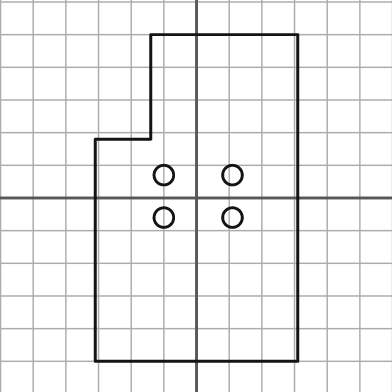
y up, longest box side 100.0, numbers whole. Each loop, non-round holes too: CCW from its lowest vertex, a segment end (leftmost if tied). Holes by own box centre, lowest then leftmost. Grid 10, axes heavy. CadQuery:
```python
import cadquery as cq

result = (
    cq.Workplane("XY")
    .moveTo(-31.0, -50.0)
    .lineTo(31.0, -50.0)
    .lineTo(31.0, 50.0)
    .lineTo(-14.0, 50.0)
    .lineTo(-14.0, 18.0)
    .lineTo(-31.0, 18.0)
    .close()
    .moveTo(-10.0, -6.0)
    .circle(3.0)
    .moveTo(11.0, -6.0)
    .circle(3.0)
    .moveTo(-10.0, 7.0)
    .circle(3.0)
    .moveTo(11.0, 7.0)
    .circle(3.0)
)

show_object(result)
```